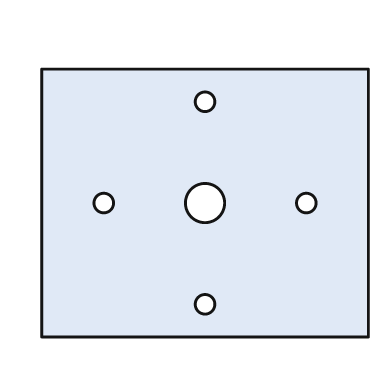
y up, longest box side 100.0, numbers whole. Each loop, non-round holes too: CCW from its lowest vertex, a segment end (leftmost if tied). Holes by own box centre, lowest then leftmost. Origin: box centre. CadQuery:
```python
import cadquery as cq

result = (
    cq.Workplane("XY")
    .moveTo(-50.0, -41.0)
    .lineTo(50.0, -41.0)
    .lineTo(50.0, 41.0)
    .lineTo(-50.0, 41.0)
    .close()
    .moveTo(0.0, -31.0)
    .circle(3.0)
    .moveTo(-31.0, 0.0)
    .circle(3.0)
    .moveTo(0.0, 0.0)
    .circle(6.0)
    .moveTo(31.0, 0.0)
    .circle(3.0)
    .moveTo(0.0, 31.0)
    .circle(3.0)
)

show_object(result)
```